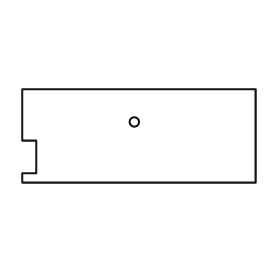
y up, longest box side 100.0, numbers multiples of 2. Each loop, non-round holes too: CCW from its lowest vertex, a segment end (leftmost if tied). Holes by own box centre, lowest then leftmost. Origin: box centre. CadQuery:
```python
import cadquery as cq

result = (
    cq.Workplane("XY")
    .moveTo(-50.0, -20.0)
    .lineTo(50.0, -20.0)
    .lineTo(50.0, 20.0)
    .lineTo(-50.0, 20.0)
    .lineTo(-50.0, -2.0)
    .lineTo(-44.0, -2.0)
    .lineTo(-44.0, -16.0)
    .lineTo(-50.0, -16.0)
    .close()
    .moveTo(-2.0, 6.0)
    .circle(2.0)
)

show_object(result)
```